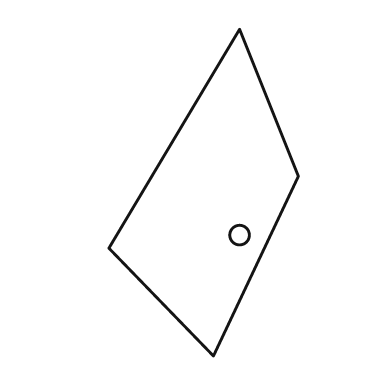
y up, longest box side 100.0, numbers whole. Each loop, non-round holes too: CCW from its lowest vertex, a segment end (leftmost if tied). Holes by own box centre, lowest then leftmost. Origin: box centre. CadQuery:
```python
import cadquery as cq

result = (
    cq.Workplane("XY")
    .moveTo(3.0, -50.0)
    .lineTo(29.0, 5.0)
    .lineTo(11.0, 50.0)
    .lineTo(-29.0, -17.0)
    .close()
    .moveTo(11.0, -13.0)
    .circle(3.0)
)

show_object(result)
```